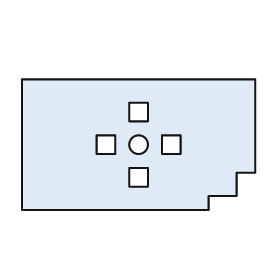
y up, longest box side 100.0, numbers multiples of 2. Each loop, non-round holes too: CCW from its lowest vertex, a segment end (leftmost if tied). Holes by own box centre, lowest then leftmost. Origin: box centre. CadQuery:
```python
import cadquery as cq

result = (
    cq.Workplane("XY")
    .moveTo(-50.0, -28.0)
    .lineTo(30.0, -28.0)
    .lineTo(30.0, -22.0)
    .lineTo(42.0, -22.0)
    .lineTo(42.0, -12.0)
    .lineTo(50.0, -12.0)
    .lineTo(50.0, 28.0)
    .lineTo(-50.0, 28.0)
    .close()
    .moveTo(-4.0, -18.0)
    .lineTo(4.0, -18.0)
    .lineTo(4.0, -10.0)
    .lineTo(-4.0, -10.0)
    .close()
    .moveTo(-18.0, -4.0)
    .lineTo(-10.0, -4.0)
    .lineTo(-10.0, 4.0)
    .lineTo(-18.0, 4.0)
    .close()
    .moveTo(0.0, 0.0)
    .circle(4.0)
    .moveTo(10.0, -4.0)
    .lineTo(18.0, -4.0)
    .lineTo(18.0, 4.0)
    .lineTo(10.0, 4.0)
    .close()
    .moveTo(-4.0, 10.0)
    .lineTo(4.0, 10.0)
    .lineTo(4.0, 18.0)
    .lineTo(-4.0, 18.0)
    .close()
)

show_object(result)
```